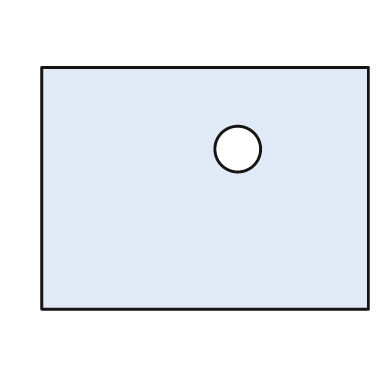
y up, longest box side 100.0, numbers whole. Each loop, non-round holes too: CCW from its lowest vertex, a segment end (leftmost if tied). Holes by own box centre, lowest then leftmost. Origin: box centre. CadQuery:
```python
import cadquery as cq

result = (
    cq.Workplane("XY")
    .moveTo(-50.0, -37.0)
    .lineTo(50.0, -37.0)
    .lineTo(50.0, 37.0)
    .lineTo(-50.0, 37.0)
    .close()
    .moveTo(10.0, 12.0)
    .circle(7.0)
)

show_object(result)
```